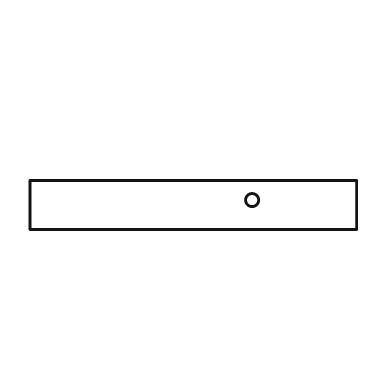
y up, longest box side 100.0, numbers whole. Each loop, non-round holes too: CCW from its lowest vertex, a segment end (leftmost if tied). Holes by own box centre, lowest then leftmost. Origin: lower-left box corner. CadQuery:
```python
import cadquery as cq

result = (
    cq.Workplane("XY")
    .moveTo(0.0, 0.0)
    .lineTo(100.0, 0.0)
    .lineTo(100.0, 15.0)
    .lineTo(0.0, 15.0)
    .close()
    .moveTo(68.0, 9.0)
    .circle(2.0)
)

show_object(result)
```